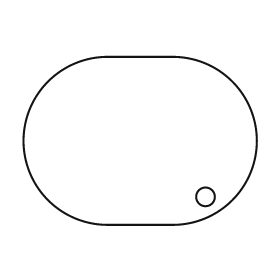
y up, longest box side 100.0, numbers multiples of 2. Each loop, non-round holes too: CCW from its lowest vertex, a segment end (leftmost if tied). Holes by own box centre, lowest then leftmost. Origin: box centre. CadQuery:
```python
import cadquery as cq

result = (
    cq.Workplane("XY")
    .moveTo(-14.0, -36.0)
    .lineTo(14.0, -36.0)
    .threePointArc((50.0, 0.0), (14.0, 36.0))
    .lineTo(-14.0, 36.0)
    .threePointArc((-50.0, 0.0), (-14.0, -36.0))
    .close()
    .moveTo(28.0, -24.0)
    .circle(4.0)
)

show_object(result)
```